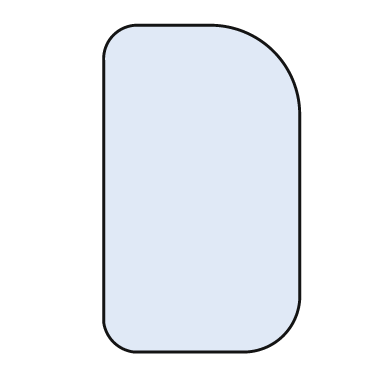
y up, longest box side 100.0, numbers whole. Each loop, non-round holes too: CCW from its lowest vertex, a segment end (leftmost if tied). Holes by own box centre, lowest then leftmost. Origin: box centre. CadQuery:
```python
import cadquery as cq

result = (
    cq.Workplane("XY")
    .moveTo(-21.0, -50.0)
    .lineTo(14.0, -50.0)
    .threePointArc((25.0, -45.0), (30.0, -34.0))
    .lineTo(30.0, 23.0)
    .threePointArc((22.0, 42.0), (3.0, 50.0))
    .lineTo(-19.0, 50.0)
    .threePointArc((-27.0, 47.0), (-30.0, 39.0))
    .lineTo(-30.0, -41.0)
    .threePointArc((-27.0, -47.0), (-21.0, -50.0))
    .close()
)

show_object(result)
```